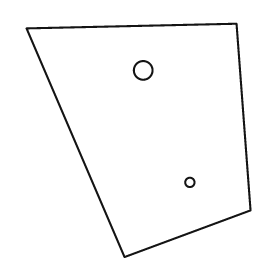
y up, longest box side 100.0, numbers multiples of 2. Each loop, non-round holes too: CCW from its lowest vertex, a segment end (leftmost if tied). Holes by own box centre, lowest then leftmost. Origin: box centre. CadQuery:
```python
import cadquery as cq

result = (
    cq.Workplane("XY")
    .moveTo(-6.0, -50.0)
    .lineTo(48.0, -30.0)
    .lineTo(42.0, 50.0)
    .lineTo(-48.0, 48.0)
    .close()
    .moveTo(22.0, -18.0)
    .circle(2.0)
    .moveTo(2.0, 30.0)
    .circle(4.0)
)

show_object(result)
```